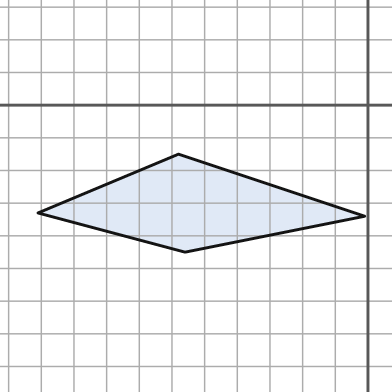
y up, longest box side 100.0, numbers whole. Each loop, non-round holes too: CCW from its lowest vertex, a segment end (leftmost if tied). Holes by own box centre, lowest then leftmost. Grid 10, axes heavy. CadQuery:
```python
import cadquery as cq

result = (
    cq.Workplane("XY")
    .moveTo(-56.0, -45.0)
    .lineTo(-1.0, -34.0)
    .lineTo(-58.0, -15.0)
    .lineTo(-101.0, -33.0)
    .close()
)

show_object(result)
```